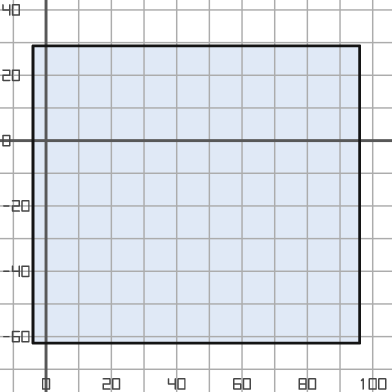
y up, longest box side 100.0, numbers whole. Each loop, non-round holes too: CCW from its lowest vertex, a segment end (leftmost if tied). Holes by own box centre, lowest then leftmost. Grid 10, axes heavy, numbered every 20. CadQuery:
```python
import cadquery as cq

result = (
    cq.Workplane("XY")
    .moveTo(-4.0, -62.0)
    .lineTo(96.0, -62.0)
    .lineTo(96.0, 29.0)
    .lineTo(-4.0, 29.0)
    .close()
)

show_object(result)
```